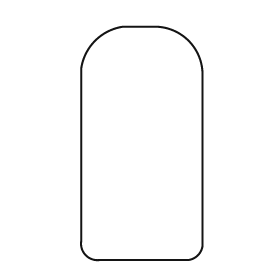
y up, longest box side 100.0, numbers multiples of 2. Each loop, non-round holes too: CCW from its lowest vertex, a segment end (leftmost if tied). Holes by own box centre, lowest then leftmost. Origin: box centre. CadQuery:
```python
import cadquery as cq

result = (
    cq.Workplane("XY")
    .moveTo(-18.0, -50.0)
    .lineTo(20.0, -50.0)
    .threePointArc((24.0, -48.0), (26.0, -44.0))
    .lineTo(26.0, 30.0)
    .threePointArc((20.0, 44.0), (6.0, 50.0))
    .lineTo(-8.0, 50.0)
    .threePointArc((-20.0, 44.0), (-26.0, 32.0))
    .lineTo(-26.0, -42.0)
    .threePointArc((-24.0, -48.0), (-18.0, -50.0))
    .close()
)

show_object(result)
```